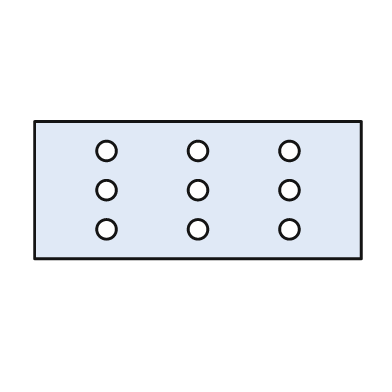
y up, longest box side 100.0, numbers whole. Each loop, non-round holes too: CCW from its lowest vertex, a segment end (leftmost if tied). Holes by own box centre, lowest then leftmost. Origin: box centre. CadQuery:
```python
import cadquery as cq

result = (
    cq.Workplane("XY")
    .moveTo(-50.0, -21.0)
    .lineTo(50.0, -21.0)
    .lineTo(50.0, 21.0)
    .lineTo(-50.0, 21.0)
    .close()
    .moveTo(-28.0, -12.0)
    .circle(3.0)
    .moveTo(0.0, -12.0)
    .circle(3.0)
    .moveTo(28.0, -12.0)
    .circle(3.0)
    .moveTo(-28.0, 0.0)
    .circle(3.0)
    .moveTo(0.0, 0.0)
    .circle(3.0)
    .moveTo(28.0, 0.0)
    .circle(3.0)
    .moveTo(-28.0, 12.0)
    .circle(3.0)
    .moveTo(0.0, 12.0)
    .circle(3.0)
    .moveTo(28.0, 12.0)
    .circle(3.0)
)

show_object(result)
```